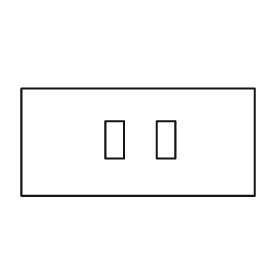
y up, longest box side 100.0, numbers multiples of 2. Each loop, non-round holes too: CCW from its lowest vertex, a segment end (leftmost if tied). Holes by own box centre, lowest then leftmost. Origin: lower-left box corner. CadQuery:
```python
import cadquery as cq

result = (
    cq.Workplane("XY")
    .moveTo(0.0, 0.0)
    .lineTo(100.0, 0.0)
    .lineTo(100.0, 46.0)
    .lineTo(0.0, 46.0)
    .close()
    .moveTo(36.0, 16.0)
    .lineTo(44.0, 16.0)
    .lineTo(44.0, 32.0)
    .lineTo(36.0, 32.0)
    .close()
    .moveTo(58.0, 16.0)
    .lineTo(66.0, 16.0)
    .lineTo(66.0, 32.0)
    .lineTo(58.0, 32.0)
    .close()
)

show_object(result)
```